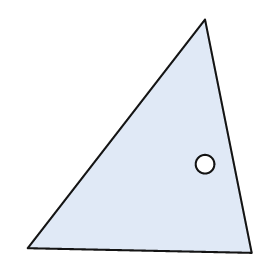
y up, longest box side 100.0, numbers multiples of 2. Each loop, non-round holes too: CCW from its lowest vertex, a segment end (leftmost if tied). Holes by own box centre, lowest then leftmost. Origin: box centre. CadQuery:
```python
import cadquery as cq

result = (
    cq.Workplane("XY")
    .moveTo(48.0, -50.0)
    .lineTo(28.0, 50.0)
    .lineTo(-48.0, -48.0)
    .close()
    .moveTo(28.0, -12.0)
    .circle(4.0)
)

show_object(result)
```